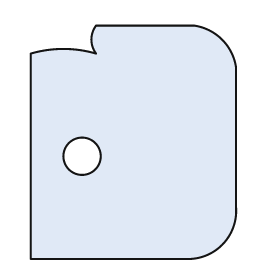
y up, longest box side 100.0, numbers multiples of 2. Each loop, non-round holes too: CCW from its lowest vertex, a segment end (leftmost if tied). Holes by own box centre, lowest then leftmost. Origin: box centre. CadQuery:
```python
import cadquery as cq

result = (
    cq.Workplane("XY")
    .moveTo(-44.0, -50.0)
    .lineTo(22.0, -50.0)
    .threePointArc((38.0, -44.0), (44.0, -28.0))
    .lineTo(44.0, 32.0)
    .threePointArc((38.0, 44.0), (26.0, 50.0))
    .lineTo(-16.0, 50.0)
    .threePointArc((-18.0, 44.0), (-16.0, 38.0))
    .threePointArc((-30.0, 40.0), (-44.0, 38.0))
    .close()
    .moveTo(-22.0, -6.0)
    .circle(8.0)
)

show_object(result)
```